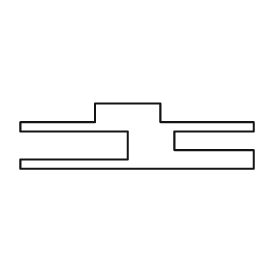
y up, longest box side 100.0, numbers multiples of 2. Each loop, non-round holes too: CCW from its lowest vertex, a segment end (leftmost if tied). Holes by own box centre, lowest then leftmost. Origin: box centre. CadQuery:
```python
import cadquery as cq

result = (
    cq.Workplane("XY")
    .moveTo(-50.0, -14.0)
    .lineTo(50.0, -14.0)
    .lineTo(50.0, -6.0)
    .lineTo(16.0, -6.0)
    .lineTo(16.0, 2.0)
    .lineTo(50.0, 2.0)
    .lineTo(50.0, 6.0)
    .lineTo(10.0, 6.0)
    .lineTo(10.0, 14.0)
    .lineTo(-18.0, 14.0)
    .lineTo(-18.0, 6.0)
    .lineTo(-50.0, 6.0)
    .lineTo(-50.0, 2.0)
    .lineTo(-4.0, 2.0)
    .lineTo(-4.0, -10.0)
    .lineTo(-50.0, -10.0)
    .close()
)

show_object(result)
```